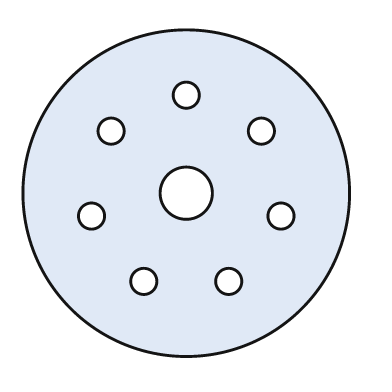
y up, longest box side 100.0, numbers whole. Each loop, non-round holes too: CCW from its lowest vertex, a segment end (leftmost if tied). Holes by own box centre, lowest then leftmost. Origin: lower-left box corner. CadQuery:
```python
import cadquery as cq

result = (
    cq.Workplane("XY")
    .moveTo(50.0, 50.0)
    .circle(50.0)
    .moveTo(37.0, 23.0)
    .circle(4.0)
    .moveTo(63.0, 23.0)
    .circle(4.0)
    .moveTo(21.0, 43.0)
    .circle(4.0)
    .moveTo(79.0, 43.0)
    .circle(4.0)
    .moveTo(50.0, 50.0)
    .circle(8.0)
    .moveTo(27.0, 69.0)
    .circle(4.0)
    .moveTo(73.0, 69.0)
    .circle(4.0)
    .moveTo(50.0, 80.0)
    .circle(4.0)
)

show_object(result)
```